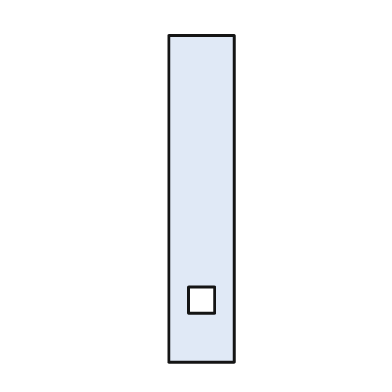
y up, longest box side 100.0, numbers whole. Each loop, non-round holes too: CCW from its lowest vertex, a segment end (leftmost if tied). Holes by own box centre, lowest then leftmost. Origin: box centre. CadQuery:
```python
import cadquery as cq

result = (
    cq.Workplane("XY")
    .moveTo(-10.0, -50.0)
    .lineTo(10.0, -50.0)
    .lineTo(10.0, 50.0)
    .lineTo(-10.0, 50.0)
    .close()
    .moveTo(-4.0, -35.0)
    .lineTo(4.0, -35.0)
    .lineTo(4.0, -27.0)
    .lineTo(-4.0, -27.0)
    .close()
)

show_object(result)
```